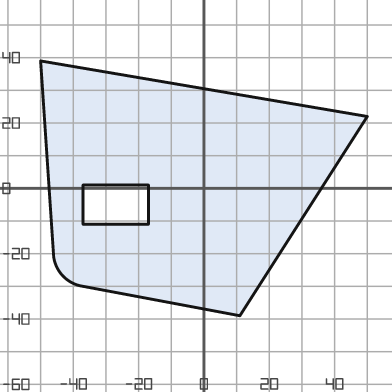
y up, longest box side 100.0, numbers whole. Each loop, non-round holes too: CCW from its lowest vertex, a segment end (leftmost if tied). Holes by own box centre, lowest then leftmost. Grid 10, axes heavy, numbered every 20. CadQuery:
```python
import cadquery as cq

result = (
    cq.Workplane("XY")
    .moveTo(11.0, -39.0)
    .lineTo(50.0, 22.0)
    .lineTo(-50.0, 39.0)
    .lineTo(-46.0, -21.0)
    .threePointArc((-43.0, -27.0), (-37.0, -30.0))
    .close()
    .moveTo(-37.0, -11.0)
    .lineTo(-17.0, -11.0)
    .lineTo(-17.0, 1.0)
    .lineTo(-37.0, 1.0)
    .close()
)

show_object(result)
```